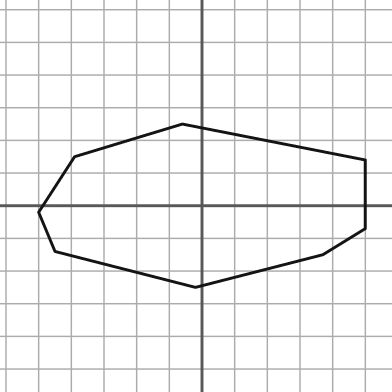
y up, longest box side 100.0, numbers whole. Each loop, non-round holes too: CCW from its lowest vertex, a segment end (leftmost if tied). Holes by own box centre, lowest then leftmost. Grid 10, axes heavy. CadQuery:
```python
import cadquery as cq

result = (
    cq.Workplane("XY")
    .moveTo(-2.0, -25.0)
    .lineTo(37.0, -15.0)
    .lineTo(50.0, -7.0)
    .lineTo(50.0, 14.0)
    .lineTo(-6.0, 25.0)
    .lineTo(-39.0, 15.0)
    .lineTo(-50.0, -2.0)
    .lineTo(-45.0, -14.0)
    .close()
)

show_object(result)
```